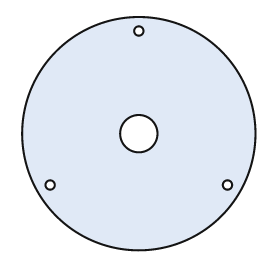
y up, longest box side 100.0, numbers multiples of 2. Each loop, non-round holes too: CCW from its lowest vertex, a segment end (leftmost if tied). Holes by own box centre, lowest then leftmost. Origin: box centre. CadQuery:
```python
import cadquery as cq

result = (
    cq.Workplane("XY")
    .moveTo(0.0, 0.0)
    .circle(50.0)
    .moveTo(-38.0, -22.0)
    .circle(2.0)
    .moveTo(38.0, -22.0)
    .circle(2.0)
    .moveTo(0.0, 0.0)
    .circle(8.0)
    .moveTo(0.0, 44.0)
    .circle(2.0)
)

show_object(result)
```